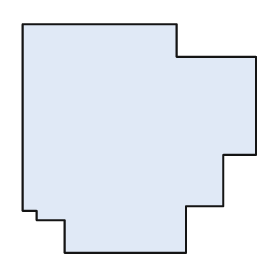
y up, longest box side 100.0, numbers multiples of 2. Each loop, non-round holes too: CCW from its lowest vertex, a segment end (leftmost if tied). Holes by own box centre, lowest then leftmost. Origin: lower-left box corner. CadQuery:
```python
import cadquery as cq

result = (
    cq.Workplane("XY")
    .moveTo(18.0, 0.0)
    .lineTo(70.0, 0.0)
    .lineTo(70.0, 20.0)
    .lineTo(86.0, 20.0)
    .lineTo(86.0, 42.0)
    .lineTo(100.0, 42.0)
    .lineTo(100.0, 84.0)
    .lineTo(66.0, 84.0)
    .lineTo(66.0, 98.0)
    .lineTo(0.0, 98.0)
    .lineTo(0.0, 18.0)
    .lineTo(6.0, 18.0)
    .lineTo(6.0, 14.0)
    .lineTo(18.0, 14.0)
    .close()
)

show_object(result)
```